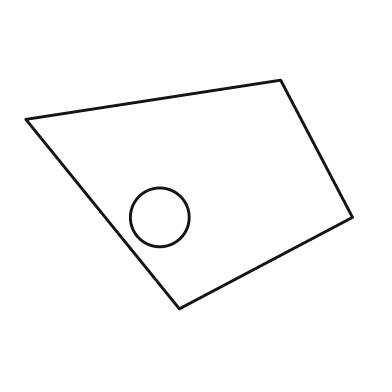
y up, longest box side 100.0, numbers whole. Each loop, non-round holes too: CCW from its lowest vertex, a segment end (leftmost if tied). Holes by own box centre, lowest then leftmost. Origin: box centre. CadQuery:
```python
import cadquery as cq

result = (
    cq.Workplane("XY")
    .moveTo(-3.0, -35.0)
    .lineTo(50.0, -7.0)
    .lineTo(28.0, 35.0)
    .lineTo(-50.0, 23.0)
    .close()
    .moveTo(-9.0, -7.0)
    .circle(9.0)
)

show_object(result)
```